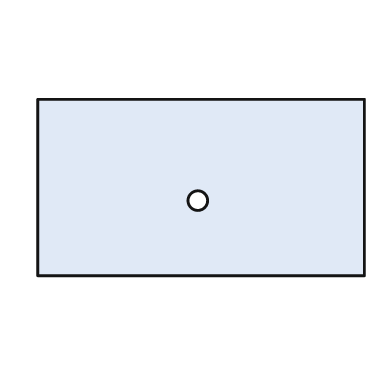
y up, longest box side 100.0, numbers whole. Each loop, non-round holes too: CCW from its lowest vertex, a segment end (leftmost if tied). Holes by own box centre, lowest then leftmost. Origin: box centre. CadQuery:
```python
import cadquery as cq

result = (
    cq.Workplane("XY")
    .moveTo(-50.0, -27.0)
    .lineTo(50.0, -27.0)
    .lineTo(50.0, 27.0)
    .lineTo(-50.0, 27.0)
    .close()
    .moveTo(-1.0, -4.0)
    .circle(3.0)
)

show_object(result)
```